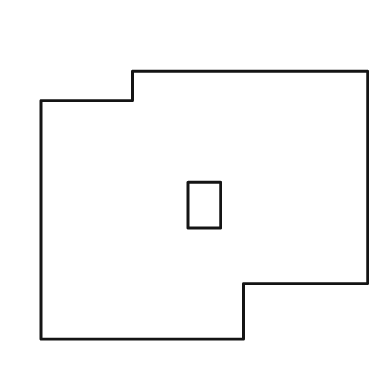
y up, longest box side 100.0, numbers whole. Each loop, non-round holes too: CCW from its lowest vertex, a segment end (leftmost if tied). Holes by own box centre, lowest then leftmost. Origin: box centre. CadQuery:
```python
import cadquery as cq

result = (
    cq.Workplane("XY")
    .moveTo(-50.0, -41.0)
    .lineTo(12.0, -41.0)
    .lineTo(12.0, -24.0)
    .lineTo(50.0, -24.0)
    .lineTo(50.0, 41.0)
    .lineTo(-22.0, 41.0)
    .lineTo(-22.0, 32.0)
    .lineTo(-50.0, 32.0)
    .close()
    .moveTo(-5.0, -7.0)
    .lineTo(5.0, -7.0)
    .lineTo(5.0, 7.0)
    .lineTo(-5.0, 7.0)
    .close()
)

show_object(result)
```